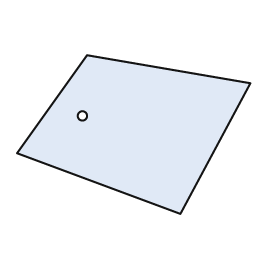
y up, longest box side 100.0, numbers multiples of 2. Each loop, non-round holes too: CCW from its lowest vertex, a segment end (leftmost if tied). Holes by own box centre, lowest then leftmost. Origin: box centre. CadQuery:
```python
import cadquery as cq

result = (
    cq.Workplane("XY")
    .moveTo(20.0, -34.0)
    .lineTo(50.0, 22.0)
    .lineTo(-20.0, 34.0)
    .lineTo(-50.0, -8.0)
    .close()
    .moveTo(-22.0, 8.0)
    .circle(2.0)
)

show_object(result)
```